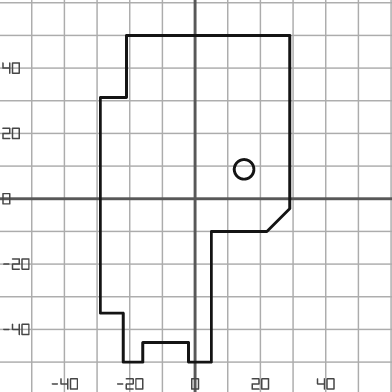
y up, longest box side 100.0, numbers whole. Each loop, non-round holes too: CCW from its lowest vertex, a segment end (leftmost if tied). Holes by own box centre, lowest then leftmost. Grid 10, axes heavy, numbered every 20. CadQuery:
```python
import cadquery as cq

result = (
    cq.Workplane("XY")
    .moveTo(-22.0, -50.0)
    .lineTo(-16.0, -50.0)
    .lineTo(-16.0, -44.0)
    .lineTo(-2.0, -44.0)
    .lineTo(-2.0, -50.0)
    .lineTo(5.0, -50.0)
    .lineTo(5.0, -10.0)
    .lineTo(22.0, -10.0)
    .lineTo(29.0, -3.0)
    .lineTo(29.0, 50.0)
    .lineTo(-21.0, 50.0)
    .lineTo(-21.0, 31.0)
    .lineTo(-29.0, 31.0)
    .lineTo(-29.0, -35.0)
    .lineTo(-22.0, -35.0)
    .close()
    .moveTo(15.0, 9.0)
    .circle(3.0)
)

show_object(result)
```